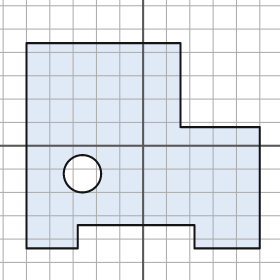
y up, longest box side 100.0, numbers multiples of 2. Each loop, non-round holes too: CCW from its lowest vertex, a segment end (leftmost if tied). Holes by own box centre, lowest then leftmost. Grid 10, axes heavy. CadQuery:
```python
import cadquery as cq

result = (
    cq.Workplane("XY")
    .moveTo(-50.0, -44.0)
    .lineTo(-28.0, -44.0)
    .lineTo(-28.0, -34.0)
    .lineTo(22.0, -34.0)
    .lineTo(22.0, -44.0)
    .lineTo(50.0, -44.0)
    .lineTo(50.0, 8.0)
    .lineTo(16.0, 8.0)
    .lineTo(16.0, 44.0)
    .lineTo(-50.0, 44.0)
    .close()
    .moveTo(-26.0, -12.0)
    .circle(8.0)
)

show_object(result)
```